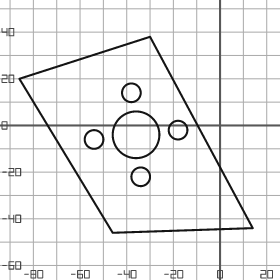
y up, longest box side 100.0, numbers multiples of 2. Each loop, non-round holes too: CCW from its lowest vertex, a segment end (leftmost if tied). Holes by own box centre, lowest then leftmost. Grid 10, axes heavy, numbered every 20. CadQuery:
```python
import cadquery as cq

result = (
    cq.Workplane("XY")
    .moveTo(-46.0, -46.0)
    .lineTo(14.0, -44.0)
    .lineTo(-30.0, 38.0)
    .lineTo(-86.0, 20.0)
    .close()
    .moveTo(-34.0, -22.0)
    .circle(4.0)
    .moveTo(-54.0, -6.0)
    .circle(4.0)
    .moveTo(-36.0, -4.0)
    .circle(10.0)
    .moveTo(-18.0, -2.0)
    .circle(4.0)
    .moveTo(-38.0, 14.0)
    .circle(4.0)
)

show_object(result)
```